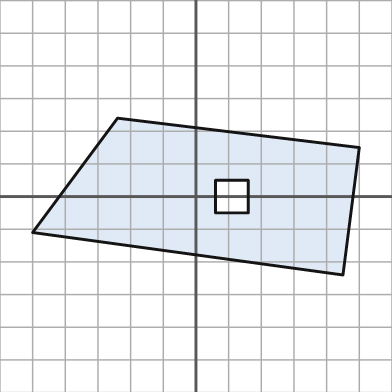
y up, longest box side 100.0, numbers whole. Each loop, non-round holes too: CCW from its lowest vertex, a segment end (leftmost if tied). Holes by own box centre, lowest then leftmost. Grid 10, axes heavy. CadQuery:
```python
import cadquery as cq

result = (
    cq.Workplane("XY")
    .moveTo(45.0, -24.0)
    .lineTo(50.0, 15.0)
    .lineTo(-24.0, 24.0)
    .lineTo(-50.0, -11.0)
    .close()
    .moveTo(6.0, -5.0)
    .lineTo(16.0, -5.0)
    .lineTo(16.0, 5.0)
    .lineTo(6.0, 5.0)
    .close()
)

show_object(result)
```